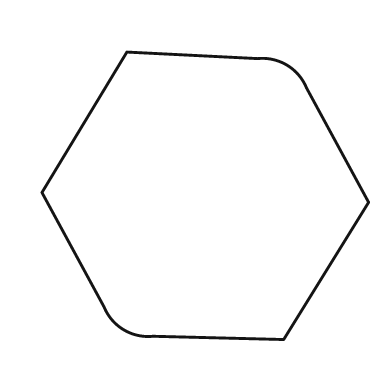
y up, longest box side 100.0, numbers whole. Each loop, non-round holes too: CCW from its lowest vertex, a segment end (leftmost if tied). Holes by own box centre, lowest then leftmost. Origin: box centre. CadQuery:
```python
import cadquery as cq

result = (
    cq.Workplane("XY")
    .moveTo(24.0, -44.0)
    .lineTo(50.0, -2.0)
    .lineTo(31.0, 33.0)
    .threePointArc((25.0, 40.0), (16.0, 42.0))
    .lineTo(-24.0, 44.0)
    .lineTo(-50.0, 1.0)
    .lineTo(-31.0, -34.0)
    .threePointArc((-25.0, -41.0), (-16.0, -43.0))
    .close()
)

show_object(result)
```